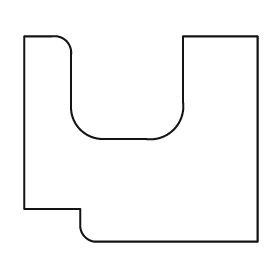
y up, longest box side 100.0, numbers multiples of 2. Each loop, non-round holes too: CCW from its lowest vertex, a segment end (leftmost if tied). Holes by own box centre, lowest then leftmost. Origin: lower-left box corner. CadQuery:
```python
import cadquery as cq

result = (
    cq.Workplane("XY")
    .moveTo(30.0, 0.0)
    .lineTo(100.0, 0.0)
    .lineTo(100.0, 88.0)
    .lineTo(68.0, 88.0)
    .lineTo(68.0, 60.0)
    .threePointArc((64.0, 48.0), (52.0, 44.0))
    .lineTo(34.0, 44.0)
    .threePointArc((24.0, 48.0), (20.0, 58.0))
    .lineTo(20.0, 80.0)
    .threePointArc((18.0, 86.0), (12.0, 88.0))
    .lineTo(0.0, 88.0)
    .lineTo(0.0, 14.0)
    .lineTo(24.0, 14.0)
    .lineTo(24.0, 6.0)
    .threePointArc((26.0, 2.0), (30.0, 0.0))
    .close()
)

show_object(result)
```